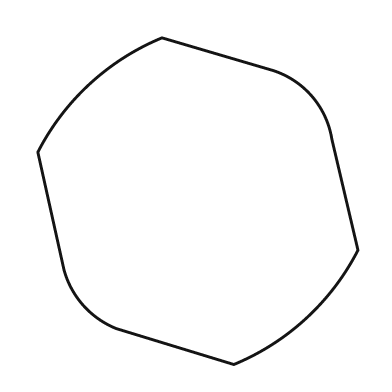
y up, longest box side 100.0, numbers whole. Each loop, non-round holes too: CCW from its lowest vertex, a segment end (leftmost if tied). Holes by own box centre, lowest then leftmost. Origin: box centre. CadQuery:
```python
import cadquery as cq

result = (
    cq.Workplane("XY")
    .moveTo(11.0, -50.0)
    .threePointArc((33.0, -36.0), (49.0, -15.0))
    .lineTo(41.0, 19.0)
    .threePointArc((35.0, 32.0), (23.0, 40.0))
    .lineTo(-11.0, 50.0)
    .threePointArc((-33.0, 36.0), (-49.0, 15.0))
    .lineTo(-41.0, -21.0)
    .threePointArc((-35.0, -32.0), (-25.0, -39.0))
    .close()
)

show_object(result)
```